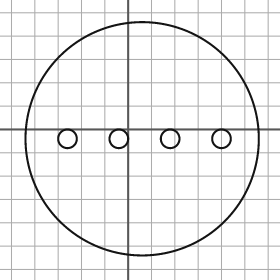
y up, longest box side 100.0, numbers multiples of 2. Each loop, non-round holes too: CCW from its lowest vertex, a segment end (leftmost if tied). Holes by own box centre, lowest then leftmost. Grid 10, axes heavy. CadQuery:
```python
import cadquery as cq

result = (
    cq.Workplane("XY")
    .moveTo(6.0, -4.0)
    .circle(50.0)
    .moveTo(-26.0, -4.0)
    .circle(4.0)
    .moveTo(-4.0, -4.0)
    .circle(4.0)
    .moveTo(18.0, -4.0)
    .circle(4.0)
    .moveTo(40.0, -4.0)
    .circle(4.0)
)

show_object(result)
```